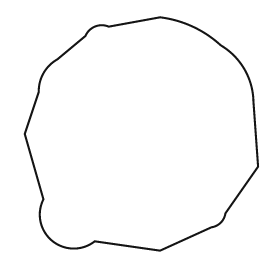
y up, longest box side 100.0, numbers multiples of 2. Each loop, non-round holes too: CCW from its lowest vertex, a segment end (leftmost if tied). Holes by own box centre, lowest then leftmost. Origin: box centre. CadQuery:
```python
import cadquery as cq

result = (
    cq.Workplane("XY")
    .moveTo(8.0, -50.0)
    .lineTo(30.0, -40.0)
    .threePointArc((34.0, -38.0), (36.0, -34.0))
    .lineTo(50.0, -14.0)
    .lineTo(48.0, 14.0)
    .threePointArc((44.0, 28.0), (34.0, 38.0))
    .threePointArc((22.0, 46.0), (8.0, 50.0))
    .lineTo(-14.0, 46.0)
    .threePointArc((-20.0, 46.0), (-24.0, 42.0))
    .lineTo(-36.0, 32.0)
    .threePointArc((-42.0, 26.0), (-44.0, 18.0))
    .lineTo(-50.0, 0.0)
    .lineTo(-42.0, -28.0)
    .threePointArc((-38.0, -46.0), (-20.0, -46.0))
    .close()
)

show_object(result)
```